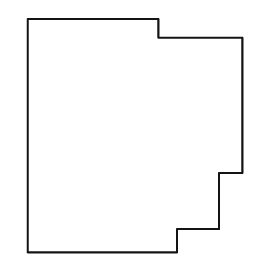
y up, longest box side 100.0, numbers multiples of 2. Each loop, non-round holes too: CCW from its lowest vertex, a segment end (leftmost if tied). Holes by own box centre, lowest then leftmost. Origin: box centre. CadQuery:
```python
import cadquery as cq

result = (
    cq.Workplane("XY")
    .moveTo(-46.0, -50.0)
    .lineTo(18.0, -50.0)
    .lineTo(18.0, -40.0)
    .lineTo(36.0, -40.0)
    .lineTo(36.0, -16.0)
    .lineTo(46.0, -16.0)
    .lineTo(46.0, 42.0)
    .lineTo(10.0, 42.0)
    .lineTo(10.0, 50.0)
    .lineTo(-46.0, 50.0)
    .close()
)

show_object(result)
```